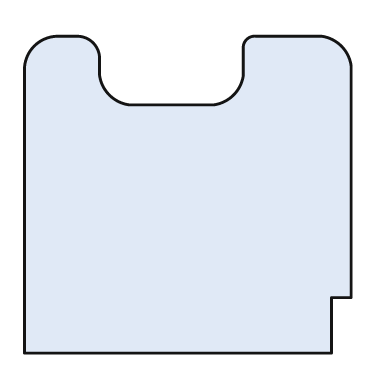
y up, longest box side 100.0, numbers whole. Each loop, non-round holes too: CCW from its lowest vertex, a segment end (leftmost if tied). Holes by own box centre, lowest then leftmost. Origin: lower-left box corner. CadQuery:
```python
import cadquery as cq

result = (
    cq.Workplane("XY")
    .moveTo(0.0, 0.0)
    .lineTo(94.0, 0.0)
    .lineTo(94.0, 17.0)
    .lineTo(100.0, 17.0)
    .lineTo(100.0, 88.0)
    .threePointArc((97.0, 94.0), (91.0, 97.0))
    .lineTo(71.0, 97.0)
    .threePointArc((68.0, 96.0), (67.0, 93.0))
    .lineTo(67.0, 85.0)
    .threePointArc((64.0, 79.0), (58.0, 76.0))
    .lineTo(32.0, 76.0)
    .threePointArc((26.0, 79.0), (23.0, 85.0))
    .lineTo(23.0, 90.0)
    .threePointArc((21.0, 95.0), (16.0, 97.0))
    .lineTo(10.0, 97.0)
    .threePointArc((3.0, 94.0), (0.0, 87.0))
    .close()
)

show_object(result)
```